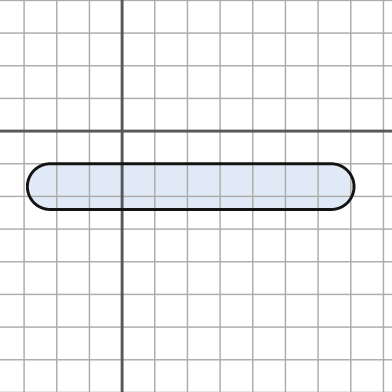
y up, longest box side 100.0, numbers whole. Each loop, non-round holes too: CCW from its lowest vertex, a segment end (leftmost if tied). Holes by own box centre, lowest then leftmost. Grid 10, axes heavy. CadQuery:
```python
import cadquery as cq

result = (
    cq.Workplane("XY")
    .moveTo(-22.0, -24.0)
    .lineTo(64.0, -24.0)
    .threePointArc((71.0, -17.0), (64.0, -10.0))
    .lineTo(-22.0, -10.0)
    .threePointArc((-29.0, -17.0), (-22.0, -24.0))
    .close()
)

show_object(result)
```